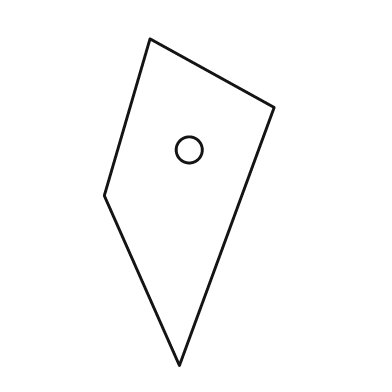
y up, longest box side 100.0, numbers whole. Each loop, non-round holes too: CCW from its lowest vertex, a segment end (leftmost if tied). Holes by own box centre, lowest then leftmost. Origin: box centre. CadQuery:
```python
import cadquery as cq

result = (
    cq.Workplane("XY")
    .moveTo(-3.0, -50.0)
    .lineTo(26.0, 29.0)
    .lineTo(-12.0, 50.0)
    .lineTo(-26.0, 2.0)
    .close()
    .moveTo(0.0, 16.0)
    .circle(4.0)
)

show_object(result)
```